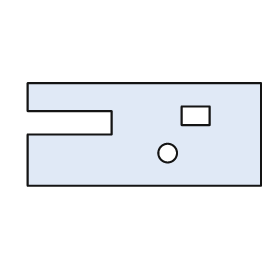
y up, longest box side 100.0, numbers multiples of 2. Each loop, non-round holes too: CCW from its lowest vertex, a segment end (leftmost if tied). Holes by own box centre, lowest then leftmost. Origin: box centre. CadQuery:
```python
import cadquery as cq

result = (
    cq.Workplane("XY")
    .moveTo(-50.0, -22.0)
    .lineTo(50.0, -22.0)
    .lineTo(50.0, 22.0)
    .lineTo(-50.0, 22.0)
    .lineTo(-50.0, 10.0)
    .lineTo(-14.0, 10.0)
    .lineTo(-14.0, 0.0)
    .lineTo(-50.0, 0.0)
    .close()
    .moveTo(10.0, -8.0)
    .circle(4.0)
    .moveTo(16.0, 4.0)
    .lineTo(28.0, 4.0)
    .lineTo(28.0, 12.0)
    .lineTo(16.0, 12.0)
    .close()
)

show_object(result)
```